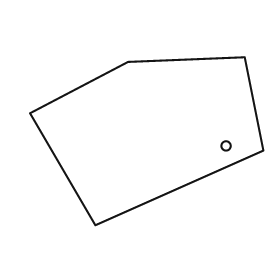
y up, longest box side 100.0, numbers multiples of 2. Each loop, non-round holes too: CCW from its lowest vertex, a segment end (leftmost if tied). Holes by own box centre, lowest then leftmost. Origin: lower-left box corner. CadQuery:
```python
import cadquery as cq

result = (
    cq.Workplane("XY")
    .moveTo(28.0, 0.0)
    .lineTo(100.0, 32.0)
    .lineTo(92.0, 72.0)
    .lineTo(42.0, 70.0)
    .lineTo(0.0, 48.0)
    .close()
    .moveTo(84.0, 34.0)
    .circle(2.0)
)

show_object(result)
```